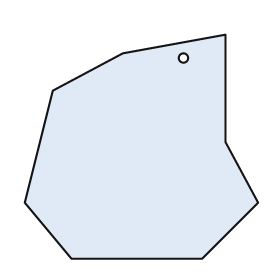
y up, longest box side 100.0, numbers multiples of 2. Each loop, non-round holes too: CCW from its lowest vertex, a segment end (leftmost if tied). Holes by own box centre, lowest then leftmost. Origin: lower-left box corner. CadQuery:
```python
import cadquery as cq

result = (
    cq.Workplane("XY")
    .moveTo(20.0, 0.0)
    .lineTo(76.0, 0.0)
    .lineTo(100.0, 24.0)
    .lineTo(86.0, 50.0)
    .lineTo(86.0, 96.0)
    .lineTo(42.0, 88.0)
    .lineTo(12.0, 72.0)
    .lineTo(0.0, 24.0)
    .close()
    .moveTo(68.0, 86.0)
    .circle(2.0)
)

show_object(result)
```